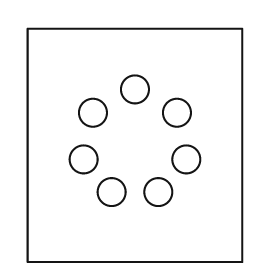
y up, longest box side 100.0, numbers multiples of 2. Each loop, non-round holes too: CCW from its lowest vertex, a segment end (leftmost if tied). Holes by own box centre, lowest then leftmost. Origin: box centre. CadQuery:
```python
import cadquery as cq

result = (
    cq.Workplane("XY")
    .moveTo(-46.0, -50.0)
    .lineTo(46.0, -50.0)
    .lineTo(46.0, 50.0)
    .lineTo(-46.0, 50.0)
    .close()
    .moveTo(-10.0, -20.0)
    .circle(6.0)
    .moveTo(10.0, -20.0)
    .circle(6.0)
    .moveTo(-22.0, -6.0)
    .circle(6.0)
    .moveTo(22.0, -6.0)
    .circle(6.0)
    .moveTo(-18.0, 14.0)
    .circle(6.0)
    .moveTo(18.0, 14.0)
    .circle(6.0)
    .moveTo(0.0, 24.0)
    .circle(6.0)
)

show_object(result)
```